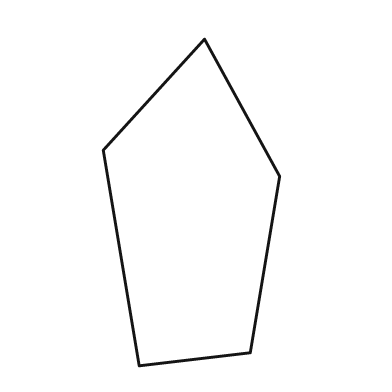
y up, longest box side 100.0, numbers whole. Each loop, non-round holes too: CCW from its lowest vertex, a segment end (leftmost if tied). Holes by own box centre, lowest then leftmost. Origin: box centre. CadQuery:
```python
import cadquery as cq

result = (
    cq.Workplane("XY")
    .moveTo(-16.0, -50.0)
    .lineTo(18.0, -46.0)
    .lineTo(27.0, 8.0)
    .lineTo(4.0, 50.0)
    .lineTo(-27.0, 16.0)
    .close()
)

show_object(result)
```